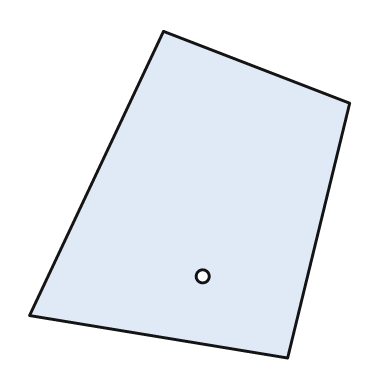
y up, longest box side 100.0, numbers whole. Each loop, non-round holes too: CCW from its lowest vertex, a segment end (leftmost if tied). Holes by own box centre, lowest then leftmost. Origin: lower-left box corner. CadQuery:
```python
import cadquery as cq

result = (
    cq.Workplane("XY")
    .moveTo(79.0, 0.0)
    .lineTo(98.0, 78.0)
    .lineTo(41.0, 100.0)
    .lineTo(0.0, 13.0)
    .close()
    .moveTo(53.0, 25.0)
    .circle(2.0)
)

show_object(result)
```